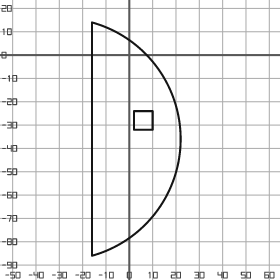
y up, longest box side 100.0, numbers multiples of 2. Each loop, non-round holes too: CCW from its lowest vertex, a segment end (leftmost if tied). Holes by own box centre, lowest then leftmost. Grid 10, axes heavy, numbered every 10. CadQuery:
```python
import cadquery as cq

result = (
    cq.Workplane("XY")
    .moveTo(-16.0, -86.0)
    .threePointArc((22.0, -36.0), (-16.0, 14.0))
    .close()
    .moveTo(2.0, -32.0)
    .lineTo(10.0, -32.0)
    .lineTo(10.0, -24.0)
    .lineTo(2.0, -24.0)
    .close()
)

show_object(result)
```